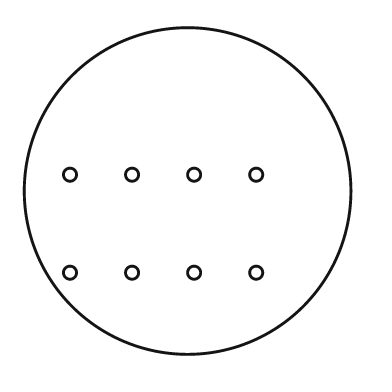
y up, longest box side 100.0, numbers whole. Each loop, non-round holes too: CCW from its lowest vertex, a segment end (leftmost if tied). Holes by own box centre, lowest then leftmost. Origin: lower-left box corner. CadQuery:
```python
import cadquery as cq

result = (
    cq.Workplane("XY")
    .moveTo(50.0, 50.0)
    .circle(50.0)
    .moveTo(14.0, 25.0)
    .circle(2.0)
    .moveTo(33.0, 25.0)
    .circle(2.0)
    .moveTo(52.0, 25.0)
    .circle(2.0)
    .moveTo(71.0, 25.0)
    .circle(2.0)
    .moveTo(14.0, 55.0)
    .circle(2.0)
    .moveTo(33.0, 55.0)
    .circle(2.0)
    .moveTo(52.0, 55.0)
    .circle(2.0)
    .moveTo(71.0, 55.0)
    .circle(2.0)
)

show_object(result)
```